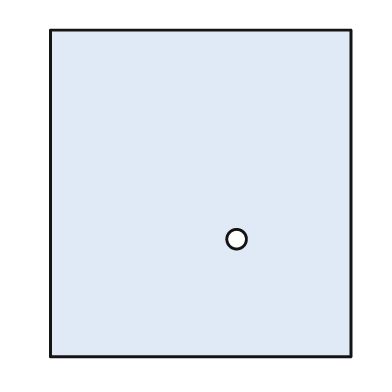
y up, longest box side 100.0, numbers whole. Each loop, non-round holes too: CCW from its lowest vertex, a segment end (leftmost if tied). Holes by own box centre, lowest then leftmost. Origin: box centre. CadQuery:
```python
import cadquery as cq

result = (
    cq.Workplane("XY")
    .moveTo(-46.0, -50.0)
    .lineTo(46.0, -50.0)
    .lineTo(46.0, 50.0)
    .lineTo(-46.0, 50.0)
    .close()
    .moveTo(11.0, -14.0)
    .circle(3.0)
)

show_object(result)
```